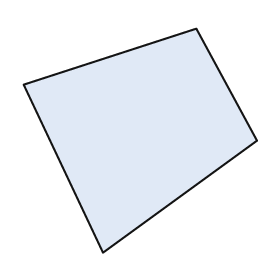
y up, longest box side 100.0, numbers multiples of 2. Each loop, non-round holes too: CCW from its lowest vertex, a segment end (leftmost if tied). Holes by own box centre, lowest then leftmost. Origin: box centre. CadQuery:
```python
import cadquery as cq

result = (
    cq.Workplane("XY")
    .moveTo(-16.0, -48.0)
    .lineTo(50.0, 0.0)
    .lineTo(24.0, 48.0)
    .lineTo(-50.0, 24.0)
    .close()
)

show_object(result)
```